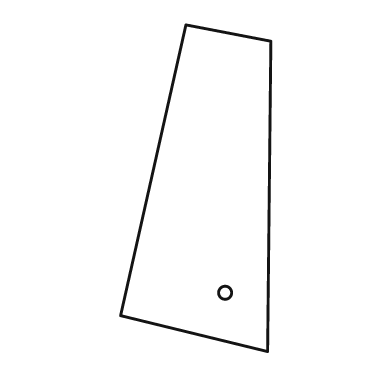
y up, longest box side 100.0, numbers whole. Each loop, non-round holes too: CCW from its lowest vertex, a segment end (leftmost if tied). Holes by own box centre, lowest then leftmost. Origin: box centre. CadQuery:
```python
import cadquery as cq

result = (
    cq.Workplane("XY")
    .moveTo(22.0, -50.0)
    .lineTo(23.0, 45.0)
    .lineTo(-3.0, 50.0)
    .lineTo(-23.0, -39.0)
    .close()
    .moveTo(9.0, -32.0)
    .circle(2.0)
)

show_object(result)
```